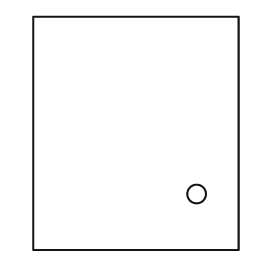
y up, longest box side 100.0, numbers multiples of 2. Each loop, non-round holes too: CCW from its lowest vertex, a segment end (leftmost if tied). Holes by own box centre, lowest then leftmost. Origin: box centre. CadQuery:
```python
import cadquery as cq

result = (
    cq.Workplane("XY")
    .moveTo(-44.0, -50.0)
    .lineTo(44.0, -50.0)
    .lineTo(44.0, 50.0)
    .lineTo(-44.0, 50.0)
    .close()
    .moveTo(26.0, -26.0)
    .circle(4.0)
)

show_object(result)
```